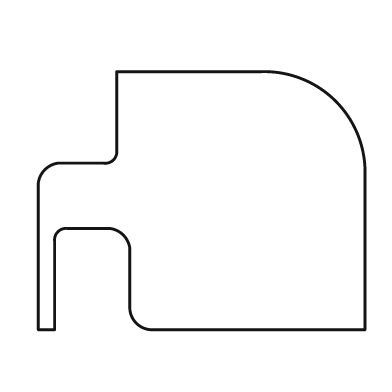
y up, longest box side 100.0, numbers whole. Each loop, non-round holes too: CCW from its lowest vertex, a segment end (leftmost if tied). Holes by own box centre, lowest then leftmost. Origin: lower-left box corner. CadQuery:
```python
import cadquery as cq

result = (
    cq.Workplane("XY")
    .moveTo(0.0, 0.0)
    .lineTo(5.0, 0.0)
    .lineTo(5.0, 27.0)
    .threePointArc((6.0, 30.0), (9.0, 31.0))
    .lineTo(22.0, 31.0)
    .threePointArc((26.0, 29.0), (28.0, 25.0))
    .lineTo(28.0, 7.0)
    .threePointArc((30.0, 2.0), (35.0, 0.0))
    .lineTo(100.0, 0.0)
    .lineTo(100.0, 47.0)
    .threePointArc((91.0, 70.0), (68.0, 79.0))
    .lineTo(24.0, 79.0)
    .lineTo(24.0, 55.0)
    .threePointArc((23.0, 52.0), (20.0, 51.0))
    .lineTo(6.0, 51.0)
    .threePointArc((2.0, 49.0), (0.0, 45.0))
    .close()
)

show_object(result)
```